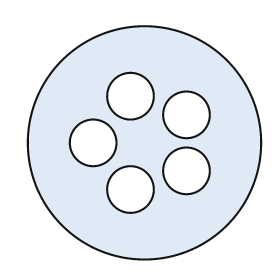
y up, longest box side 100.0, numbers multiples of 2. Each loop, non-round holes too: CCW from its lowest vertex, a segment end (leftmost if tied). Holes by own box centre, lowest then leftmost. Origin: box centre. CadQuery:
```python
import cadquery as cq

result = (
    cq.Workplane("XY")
    .moveTo(0.0, 0.0)
    .circle(50.0)
    .moveTo(-6.0, -20.0)
    .circle(10.0)
    .moveTo(18.0, -12.0)
    .circle(10.0)
    .moveTo(-22.0, 0.0)
    .circle(10.0)
    .moveTo(18.0, 12.0)
    .circle(10.0)
    .moveTo(-6.0, 20.0)
    .circle(10.0)
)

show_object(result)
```